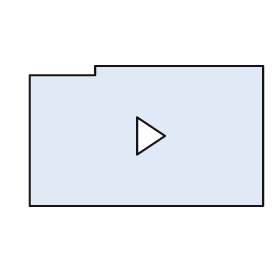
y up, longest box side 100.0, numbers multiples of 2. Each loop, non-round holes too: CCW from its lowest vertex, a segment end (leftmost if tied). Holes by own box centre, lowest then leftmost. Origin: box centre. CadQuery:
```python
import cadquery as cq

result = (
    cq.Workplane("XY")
    .moveTo(-50.0, -30.0)
    .lineTo(50.0, -30.0)
    .lineTo(50.0, 30.0)
    .lineTo(-22.0, 30.0)
    .lineTo(-22.0, 26.0)
    .lineTo(-50.0, 26.0)
    .close()
    .moveTo(-4.0, -8.0)
    .lineTo(8.0, 0.0)
    .lineTo(-4.0, 8.0)
    .close()
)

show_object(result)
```